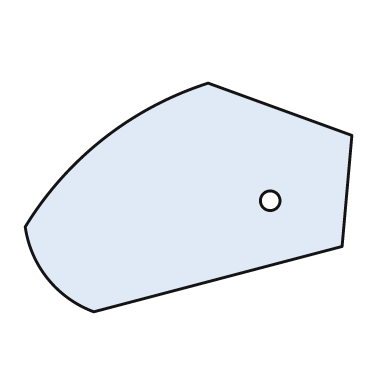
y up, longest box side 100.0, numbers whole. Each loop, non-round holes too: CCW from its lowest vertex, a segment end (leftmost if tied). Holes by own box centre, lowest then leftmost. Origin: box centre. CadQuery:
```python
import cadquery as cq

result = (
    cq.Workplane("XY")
    .moveTo(-29.0, -35.0)
    .lineTo(47.0, -15.0)
    .lineTo(50.0, 19.0)
    .lineTo(6.0, 35.0)
    .threePointArc((-26.0, 18.0), (-50.0, -9.0))
    .threePointArc((-43.0, -25.0), (-29.0, -35.0))
    .close()
    .moveTo(25.0, -1.0)
    .circle(3.0)
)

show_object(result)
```